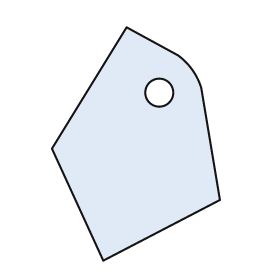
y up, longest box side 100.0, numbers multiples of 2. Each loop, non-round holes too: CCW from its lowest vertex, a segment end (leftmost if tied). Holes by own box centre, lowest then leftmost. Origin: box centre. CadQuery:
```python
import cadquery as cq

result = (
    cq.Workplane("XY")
    .moveTo(-14.0, -50.0)
    .lineTo(36.0, -24.0)
    .lineTo(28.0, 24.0)
    .threePointArc((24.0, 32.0), (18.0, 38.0))
    .lineTo(-4.0, 50.0)
    .lineTo(-36.0, -2.0)
    .close()
    .moveTo(10.0, 22.0)
    .circle(6.0)
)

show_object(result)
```